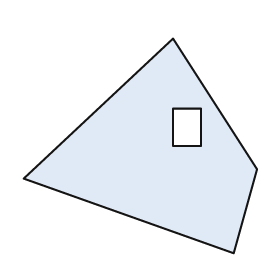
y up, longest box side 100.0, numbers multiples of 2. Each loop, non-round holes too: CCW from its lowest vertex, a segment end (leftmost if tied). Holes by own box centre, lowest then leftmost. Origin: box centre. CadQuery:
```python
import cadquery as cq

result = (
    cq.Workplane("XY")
    .moveTo(40.0, -46.0)
    .lineTo(50.0, -10.0)
    .lineTo(14.0, 46.0)
    .lineTo(-50.0, -14.0)
    .close()
    .moveTo(14.0, 0.0)
    .lineTo(26.0, 0.0)
    .lineTo(26.0, 16.0)
    .lineTo(14.0, 16.0)
    .close()
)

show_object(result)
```